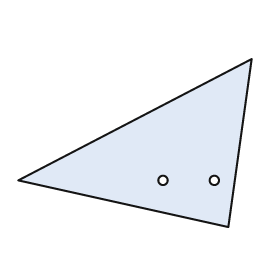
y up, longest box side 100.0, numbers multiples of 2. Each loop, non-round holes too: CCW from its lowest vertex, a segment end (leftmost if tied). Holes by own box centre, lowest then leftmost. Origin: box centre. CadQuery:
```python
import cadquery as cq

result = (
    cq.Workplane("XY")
    .moveTo(40.0, -36.0)
    .lineTo(50.0, 36.0)
    .lineTo(-50.0, -16.0)
    .close()
    .moveTo(12.0, -16.0)
    .circle(2.0)
    .moveTo(34.0, -16.0)
    .circle(2.0)
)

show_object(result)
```